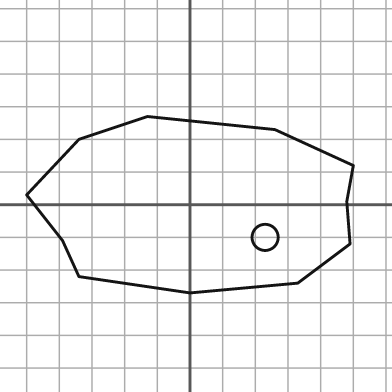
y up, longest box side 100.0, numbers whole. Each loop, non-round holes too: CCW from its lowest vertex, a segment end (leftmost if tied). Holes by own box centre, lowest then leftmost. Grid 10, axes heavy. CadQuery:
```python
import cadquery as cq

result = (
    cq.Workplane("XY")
    .moveTo(0.0, -27.0)
    .lineTo(33.0, -24.0)
    .lineTo(49.0, -12.0)
    .lineTo(48.0, 1.0)
    .lineTo(50.0, 12.0)
    .lineTo(26.0, 23.0)
    .lineTo(-13.0, 27.0)
    .lineTo(-34.0, 20.0)
    .lineTo(-50.0, 3.0)
    .lineTo(-39.0, -11.0)
    .lineTo(-34.0, -22.0)
    .close()
    .moveTo(23.0, -10.0)
    .circle(4.0)
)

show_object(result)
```